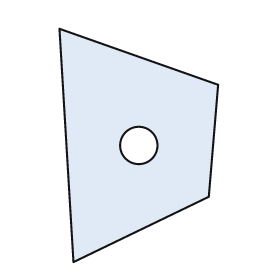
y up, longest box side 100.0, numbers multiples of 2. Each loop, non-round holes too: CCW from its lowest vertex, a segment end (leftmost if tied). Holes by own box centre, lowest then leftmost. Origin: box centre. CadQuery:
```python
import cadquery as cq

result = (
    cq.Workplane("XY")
    .moveTo(-28.0, -50.0)
    .lineTo(30.0, -22.0)
    .lineTo(34.0, 26.0)
    .lineTo(-34.0, 50.0)
    .close()
    .moveTo(0.0, 0.0)
    .circle(8.0)
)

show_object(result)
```